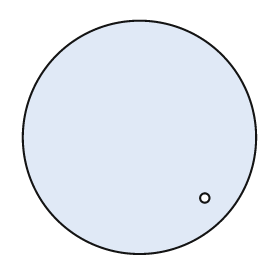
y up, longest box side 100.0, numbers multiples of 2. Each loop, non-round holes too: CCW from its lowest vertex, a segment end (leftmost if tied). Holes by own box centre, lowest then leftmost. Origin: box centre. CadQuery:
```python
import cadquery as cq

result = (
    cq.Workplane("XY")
    .moveTo(0.0, 0.0)
    .circle(50.0)
    .moveTo(28.0, -26.0)
    .circle(2.0)
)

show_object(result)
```